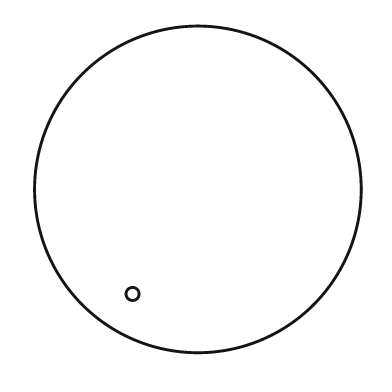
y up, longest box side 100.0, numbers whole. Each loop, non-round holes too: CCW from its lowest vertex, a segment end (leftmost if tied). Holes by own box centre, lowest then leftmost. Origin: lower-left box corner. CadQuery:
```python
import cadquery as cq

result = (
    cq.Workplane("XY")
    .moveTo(50.0, 50.0)
    .circle(50.0)
    .moveTo(30.0, 18.0)
    .circle(2.0)
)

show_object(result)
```